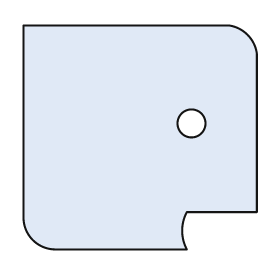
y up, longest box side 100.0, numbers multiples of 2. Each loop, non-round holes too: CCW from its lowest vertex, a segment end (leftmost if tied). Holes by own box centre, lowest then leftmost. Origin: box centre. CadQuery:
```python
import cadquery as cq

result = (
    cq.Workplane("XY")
    .moveTo(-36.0, -48.0)
    .lineTo(20.0, -48.0)
    .threePointArc((18.0, -40.0), (20.0, -32.0))
    .lineTo(50.0, -32.0)
    .lineTo(50.0, 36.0)
    .threePointArc((46.0, 44.0), (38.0, 48.0))
    .lineTo(-50.0, 48.0)
    .lineTo(-50.0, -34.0)
    .threePointArc((-46.0, -44.0), (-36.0, -48.0))
    .close()
    .moveTo(22.0, 6.0)
    .circle(6.0)
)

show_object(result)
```